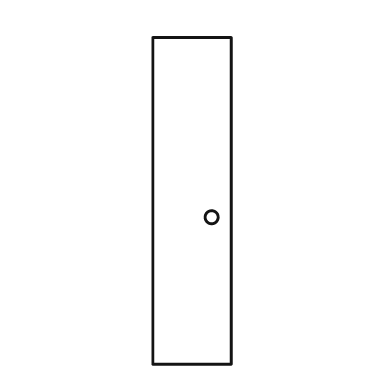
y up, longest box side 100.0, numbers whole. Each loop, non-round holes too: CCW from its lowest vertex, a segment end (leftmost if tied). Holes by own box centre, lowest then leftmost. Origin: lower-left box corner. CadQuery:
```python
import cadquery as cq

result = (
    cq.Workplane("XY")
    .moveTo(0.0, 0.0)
    .lineTo(24.0, 0.0)
    .lineTo(24.0, 100.0)
    .lineTo(0.0, 100.0)
    .close()
    .moveTo(18.0, 45.0)
    .circle(2.0)
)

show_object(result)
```